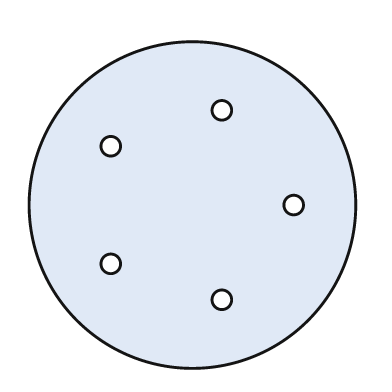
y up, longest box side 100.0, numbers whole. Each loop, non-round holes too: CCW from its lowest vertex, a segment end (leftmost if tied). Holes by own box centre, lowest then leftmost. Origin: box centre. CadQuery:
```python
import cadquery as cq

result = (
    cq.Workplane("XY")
    .moveTo(0.0, 0.0)
    .circle(50.0)
    .moveTo(9.0, -29.0)
    .circle(3.0)
    .moveTo(-25.0, -18.0)
    .circle(3.0)
    .moveTo(31.0, 0.0)
    .circle(3.0)
    .moveTo(-25.0, 18.0)
    .circle(3.0)
    .moveTo(9.0, 29.0)
    .circle(3.0)
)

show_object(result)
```